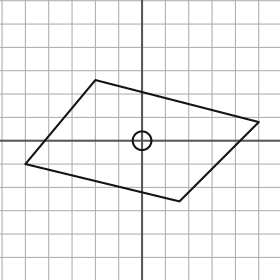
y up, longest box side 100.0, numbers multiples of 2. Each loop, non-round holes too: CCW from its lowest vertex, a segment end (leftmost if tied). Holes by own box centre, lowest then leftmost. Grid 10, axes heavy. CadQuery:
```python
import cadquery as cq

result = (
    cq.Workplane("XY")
    .moveTo(16.0, -26.0)
    .lineTo(50.0, 8.0)
    .lineTo(-20.0, 26.0)
    .lineTo(-50.0, -10.0)
    .close()
    .moveTo(0.0, 0.0)
    .circle(4.0)
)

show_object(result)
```